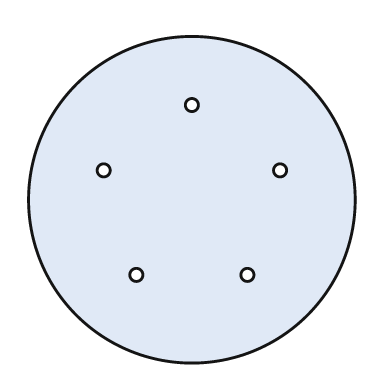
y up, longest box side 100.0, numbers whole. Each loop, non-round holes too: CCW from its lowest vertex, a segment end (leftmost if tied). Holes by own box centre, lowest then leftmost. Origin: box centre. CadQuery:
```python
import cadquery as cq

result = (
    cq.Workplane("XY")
    .moveTo(0.0, 0.0)
    .circle(50.0)
    .moveTo(-17.0, -23.0)
    .circle(2.0)
    .moveTo(17.0, -23.0)
    .circle(2.0)
    .moveTo(-27.0, 9.0)
    .circle(2.0)
    .moveTo(27.0, 9.0)
    .circle(2.0)
    .moveTo(0.0, 29.0)
    .circle(2.0)
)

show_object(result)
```